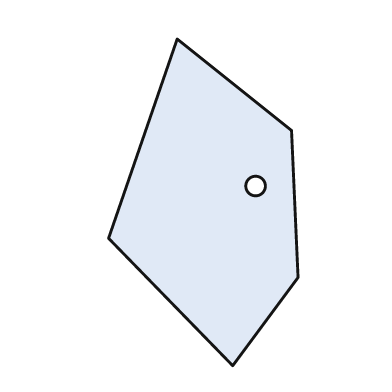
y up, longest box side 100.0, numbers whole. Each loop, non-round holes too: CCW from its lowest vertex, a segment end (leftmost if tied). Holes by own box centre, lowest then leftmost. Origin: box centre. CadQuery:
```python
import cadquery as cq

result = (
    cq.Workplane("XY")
    .moveTo(9.0, -50.0)
    .lineTo(29.0, -23.0)
    .lineTo(27.0, 22.0)
    .lineTo(-8.0, 50.0)
    .lineTo(-29.0, -11.0)
    .close()
    .moveTo(16.0, 5.0)
    .circle(3.0)
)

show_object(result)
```